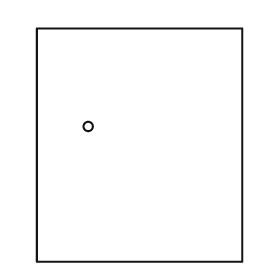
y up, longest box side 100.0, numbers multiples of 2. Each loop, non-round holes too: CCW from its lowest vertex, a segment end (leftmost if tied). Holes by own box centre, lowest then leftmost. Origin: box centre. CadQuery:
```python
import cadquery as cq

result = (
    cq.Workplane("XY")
    .moveTo(-44.0, -50.0)
    .lineTo(44.0, -50.0)
    .lineTo(44.0, 50.0)
    .lineTo(-44.0, 50.0)
    .close()
    .moveTo(-22.0, 8.0)
    .circle(2.0)
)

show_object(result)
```